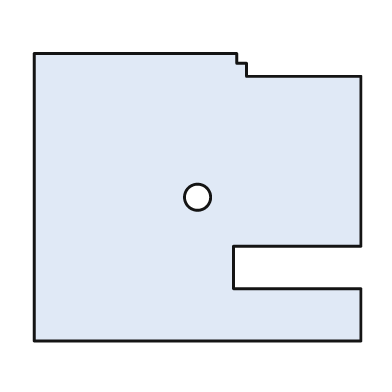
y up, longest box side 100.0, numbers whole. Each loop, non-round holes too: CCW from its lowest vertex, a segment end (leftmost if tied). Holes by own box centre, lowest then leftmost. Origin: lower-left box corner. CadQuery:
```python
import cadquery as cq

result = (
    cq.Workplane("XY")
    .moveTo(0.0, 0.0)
    .lineTo(100.0, 0.0)
    .lineTo(100.0, 16.0)
    .lineTo(61.0, 16.0)
    .lineTo(61.0, 29.0)
    .lineTo(100.0, 29.0)
    .lineTo(100.0, 81.0)
    .lineTo(65.0, 81.0)
    .lineTo(65.0, 85.0)
    .lineTo(62.0, 85.0)
    .lineTo(62.0, 88.0)
    .lineTo(0.0, 88.0)
    .close()
    .moveTo(50.0, 44.0)
    .circle(4.0)
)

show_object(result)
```